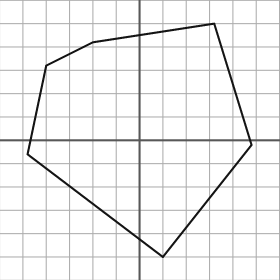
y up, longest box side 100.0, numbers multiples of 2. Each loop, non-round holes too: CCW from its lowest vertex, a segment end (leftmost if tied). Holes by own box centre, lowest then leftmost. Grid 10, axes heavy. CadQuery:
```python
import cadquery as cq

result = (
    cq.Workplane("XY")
    .moveTo(10.0, -50.0)
    .lineTo(48.0, -2.0)
    .lineTo(32.0, 50.0)
    .lineTo(-20.0, 42.0)
    .lineTo(-40.0, 32.0)
    .lineTo(-48.0, -6.0)
    .close()
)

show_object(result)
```